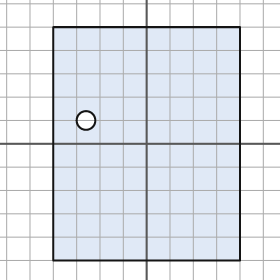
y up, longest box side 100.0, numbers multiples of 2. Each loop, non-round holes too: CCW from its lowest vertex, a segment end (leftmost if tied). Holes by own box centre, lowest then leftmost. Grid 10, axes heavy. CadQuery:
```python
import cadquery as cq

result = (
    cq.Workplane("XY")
    .moveTo(-40.0, -50.0)
    .lineTo(40.0, -50.0)
    .lineTo(40.0, 50.0)
    .lineTo(-40.0, 50.0)
    .close()
    .moveTo(-26.0, 10.0)
    .circle(4.0)
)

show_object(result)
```